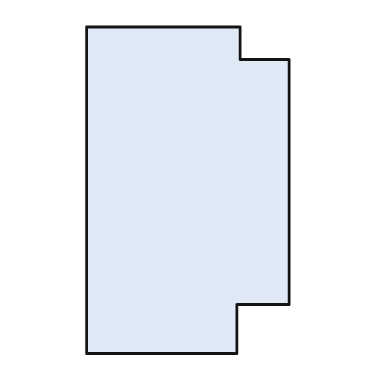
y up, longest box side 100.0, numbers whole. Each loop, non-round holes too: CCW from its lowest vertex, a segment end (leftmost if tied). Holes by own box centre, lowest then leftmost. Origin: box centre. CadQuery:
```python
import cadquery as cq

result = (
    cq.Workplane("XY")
    .moveTo(-31.0, -50.0)
    .lineTo(15.0, -50.0)
    .lineTo(15.0, -35.0)
    .lineTo(31.0, -35.0)
    .lineTo(31.0, 40.0)
    .lineTo(16.0, 40.0)
    .lineTo(16.0, 50.0)
    .lineTo(-31.0, 50.0)
    .close()
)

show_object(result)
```